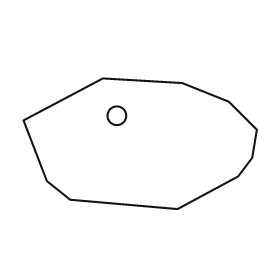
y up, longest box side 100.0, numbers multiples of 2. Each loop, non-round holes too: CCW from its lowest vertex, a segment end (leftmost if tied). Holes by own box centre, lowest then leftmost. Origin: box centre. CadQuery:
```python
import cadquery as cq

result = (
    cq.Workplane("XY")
    .moveTo(16.0, -28.0)
    .lineTo(42.0, -14.0)
    .lineTo(48.0, -6.0)
    .lineTo(50.0, 6.0)
    .lineTo(38.0, 18.0)
    .lineTo(18.0, 26.0)
    .lineTo(-16.0, 28.0)
    .lineTo(-50.0, 10.0)
    .lineTo(-40.0, -16.0)
    .lineTo(-30.0, -24.0)
    .close()
    .moveTo(-10.0, 12.0)
    .circle(4.0)
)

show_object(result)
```